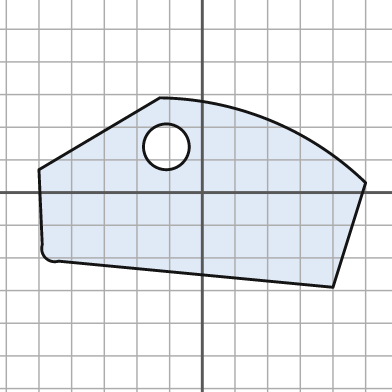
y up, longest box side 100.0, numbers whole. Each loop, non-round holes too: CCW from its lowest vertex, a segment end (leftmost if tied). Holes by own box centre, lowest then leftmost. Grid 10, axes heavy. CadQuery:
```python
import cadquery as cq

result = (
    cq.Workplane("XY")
    .moveTo(40.0, -29.0)
    .lineTo(50.0, 3.0)
    .threePointArc((21.0, 22.0), (-13.0, 29.0))
    .lineTo(-50.0, 7.0)
    .lineTo(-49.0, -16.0)
    .threePointArc((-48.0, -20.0), (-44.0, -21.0))
    .close()
    .moveTo(-11.0, 14.0)
    .circle(7.0)
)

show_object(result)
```